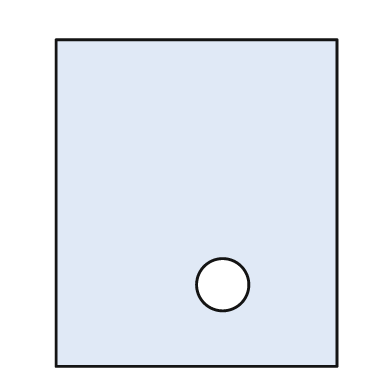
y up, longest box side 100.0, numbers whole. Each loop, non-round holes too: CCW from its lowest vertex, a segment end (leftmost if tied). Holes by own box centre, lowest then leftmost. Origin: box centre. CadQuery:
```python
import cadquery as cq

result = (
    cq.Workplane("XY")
    .moveTo(-43.0, -50.0)
    .lineTo(43.0, -50.0)
    .lineTo(43.0, 50.0)
    .lineTo(-43.0, 50.0)
    .close()
    .moveTo(8.0, -25.0)
    .circle(8.0)
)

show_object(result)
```